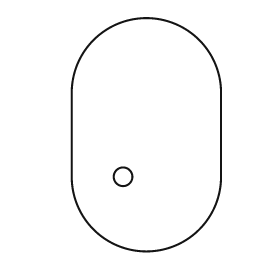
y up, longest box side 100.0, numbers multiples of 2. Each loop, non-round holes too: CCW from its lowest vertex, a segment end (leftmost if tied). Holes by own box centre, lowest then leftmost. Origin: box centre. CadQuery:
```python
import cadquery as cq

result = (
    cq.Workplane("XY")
    .moveTo(-32.0, -18.0)
    .threePointArc((0.0, -50.0), (32.0, -18.0))
    .lineTo(32.0, 18.0)
    .threePointArc((0.0, 50.0), (-32.0, 18.0))
    .close()
    .moveTo(-10.0, -18.0)
    .circle(4.0)
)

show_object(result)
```